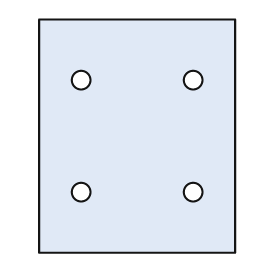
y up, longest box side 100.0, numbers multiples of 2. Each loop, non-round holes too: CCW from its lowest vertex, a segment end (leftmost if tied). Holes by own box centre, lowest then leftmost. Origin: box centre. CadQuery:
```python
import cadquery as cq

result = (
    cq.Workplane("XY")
    .moveTo(-42.0, -50.0)
    .lineTo(42.0, -50.0)
    .lineTo(42.0, 50.0)
    .lineTo(-42.0, 50.0)
    .close()
    .moveTo(-24.0, -24.0)
    .circle(4.0)
    .moveTo(24.0, -24.0)
    .circle(4.0)
    .moveTo(-24.0, 24.0)
    .circle(4.0)
    .moveTo(24.0, 24.0)
    .circle(4.0)
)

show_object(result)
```